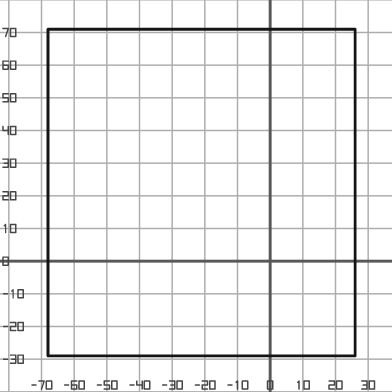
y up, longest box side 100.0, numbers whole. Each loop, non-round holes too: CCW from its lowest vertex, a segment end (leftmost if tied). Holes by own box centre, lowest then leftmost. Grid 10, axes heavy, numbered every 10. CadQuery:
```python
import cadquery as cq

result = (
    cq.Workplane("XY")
    .moveTo(-68.0, -29.0)
    .lineTo(26.0, -29.0)
    .lineTo(26.0, 71.0)
    .lineTo(-68.0, 71.0)
    .close()
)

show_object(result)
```